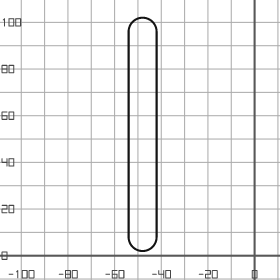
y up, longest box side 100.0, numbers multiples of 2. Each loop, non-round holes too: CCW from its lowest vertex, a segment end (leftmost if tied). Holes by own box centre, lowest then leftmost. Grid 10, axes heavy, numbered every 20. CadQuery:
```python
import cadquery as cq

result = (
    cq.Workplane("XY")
    .moveTo(-54.0, 8.0)
    .threePointArc((-48.0, 2.0), (-42.0, 8.0))
    .lineTo(-42.0, 96.0)
    .threePointArc((-48.0, 102.0), (-54.0, 96.0))
    .close()
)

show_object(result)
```